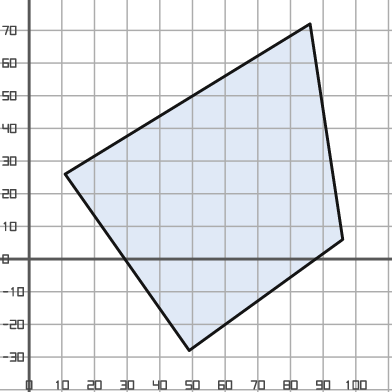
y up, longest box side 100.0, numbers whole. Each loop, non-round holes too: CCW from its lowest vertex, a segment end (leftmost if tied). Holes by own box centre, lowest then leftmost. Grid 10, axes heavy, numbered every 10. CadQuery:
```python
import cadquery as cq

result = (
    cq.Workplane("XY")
    .moveTo(49.0, -28.0)
    .lineTo(96.0, 6.0)
    .lineTo(86.0, 72.0)
    .lineTo(11.0, 26.0)
    .close()
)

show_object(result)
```